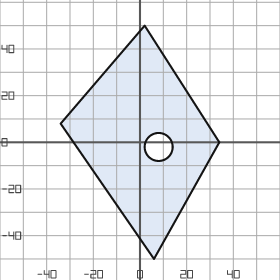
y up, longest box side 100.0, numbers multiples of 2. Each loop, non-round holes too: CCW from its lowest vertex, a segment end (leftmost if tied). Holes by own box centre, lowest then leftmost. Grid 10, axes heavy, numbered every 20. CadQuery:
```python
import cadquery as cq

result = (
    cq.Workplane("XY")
    .moveTo(6.0, -50.0)
    .lineTo(34.0, 0.0)
    .lineTo(2.0, 50.0)
    .lineTo(-34.0, 8.0)
    .close()
    .moveTo(8.0, -2.0)
    .circle(6.0)
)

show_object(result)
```